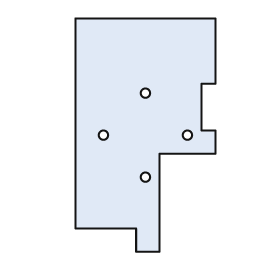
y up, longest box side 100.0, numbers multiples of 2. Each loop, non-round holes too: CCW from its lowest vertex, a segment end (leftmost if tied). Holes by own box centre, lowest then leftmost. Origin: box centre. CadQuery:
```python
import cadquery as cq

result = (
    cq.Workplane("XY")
    .moveTo(-4.0, -50.0)
    .lineTo(6.0, -50.0)
    .lineTo(6.0, -8.0)
    .lineTo(30.0, -8.0)
    .lineTo(30.0, 2.0)
    .lineTo(24.0, 2.0)
    .lineTo(24.0, 22.0)
    .lineTo(30.0, 22.0)
    .lineTo(30.0, 50.0)
    .lineTo(-30.0, 50.0)
    .lineTo(-30.0, -40.0)
    .lineTo(-4.0, -40.0)
    .close()
    .moveTo(0.0, -18.0)
    .circle(2.0)
    .moveTo(-18.0, 0.0)
    .circle(2.0)
    .moveTo(18.0, 0.0)
    .circle(2.0)
    .moveTo(0.0, 18.0)
    .circle(2.0)
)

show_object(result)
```